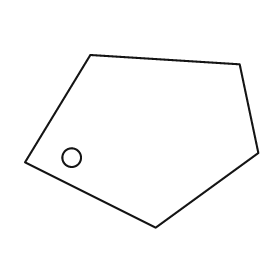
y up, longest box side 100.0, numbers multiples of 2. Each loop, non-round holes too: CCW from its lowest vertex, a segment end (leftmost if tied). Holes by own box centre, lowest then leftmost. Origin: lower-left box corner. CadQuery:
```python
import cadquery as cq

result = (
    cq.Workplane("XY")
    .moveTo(56.0, 0.0)
    .lineTo(100.0, 32.0)
    .lineTo(92.0, 70.0)
    .lineTo(28.0, 74.0)
    .lineTo(0.0, 28.0)
    .close()
    .moveTo(20.0, 30.0)
    .circle(4.0)
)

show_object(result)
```